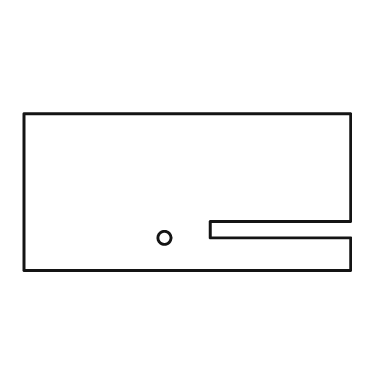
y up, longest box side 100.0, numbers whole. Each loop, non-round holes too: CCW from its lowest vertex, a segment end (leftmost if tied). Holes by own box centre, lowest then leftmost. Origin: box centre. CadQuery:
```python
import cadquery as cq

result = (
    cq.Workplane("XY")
    .moveTo(-50.0, -24.0)
    .lineTo(50.0, -24.0)
    .lineTo(50.0, -14.0)
    .lineTo(7.0, -14.0)
    .lineTo(7.0, -9.0)
    .lineTo(50.0, -9.0)
    .lineTo(50.0, 24.0)
    .lineTo(-50.0, 24.0)
    .close()
    .moveTo(-7.0, -14.0)
    .circle(2.0)
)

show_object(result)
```